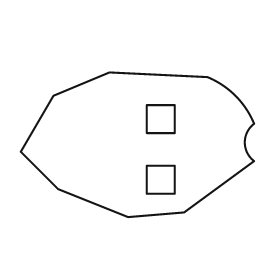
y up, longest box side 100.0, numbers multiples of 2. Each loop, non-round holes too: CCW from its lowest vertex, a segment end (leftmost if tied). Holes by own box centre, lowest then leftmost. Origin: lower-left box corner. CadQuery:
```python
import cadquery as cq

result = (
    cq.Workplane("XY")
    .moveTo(46.0, 0.0)
    .lineTo(70.0, 2.0)
    .lineTo(100.0, 24.0)
    .threePointArc((96.0, 32.0), (100.0, 40.0))
    .threePointArc((92.0, 52.0), (80.0, 60.0))
    .lineTo(38.0, 62.0)
    .lineTo(14.0, 52.0)
    .lineTo(0.0, 28.0)
    .lineTo(16.0, 12.0)
    .close()
    .moveTo(54.0, 10.0)
    .lineTo(66.0, 10.0)
    .lineTo(66.0, 22.0)
    .lineTo(54.0, 22.0)
    .close()
    .moveTo(54.0, 36.0)
    .lineTo(66.0, 36.0)
    .lineTo(66.0, 48.0)
    .lineTo(54.0, 48.0)
    .close()
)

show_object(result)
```